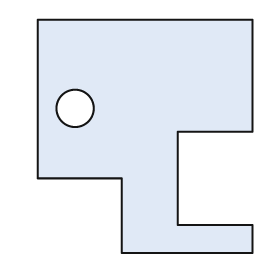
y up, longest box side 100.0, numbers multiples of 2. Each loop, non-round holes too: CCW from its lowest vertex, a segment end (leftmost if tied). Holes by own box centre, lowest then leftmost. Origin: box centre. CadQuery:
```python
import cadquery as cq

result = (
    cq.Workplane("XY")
    .moveTo(-10.0, -50.0)
    .lineTo(46.0, -50.0)
    .lineTo(46.0, -38.0)
    .lineTo(14.0, -38.0)
    .lineTo(14.0, 2.0)
    .lineTo(46.0, 2.0)
    .lineTo(46.0, 50.0)
    .lineTo(-46.0, 50.0)
    .lineTo(-46.0, -18.0)
    .lineTo(-10.0, -18.0)
    .close()
    .moveTo(-30.0, 12.0)
    .circle(8.0)
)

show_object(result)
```